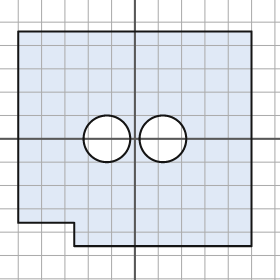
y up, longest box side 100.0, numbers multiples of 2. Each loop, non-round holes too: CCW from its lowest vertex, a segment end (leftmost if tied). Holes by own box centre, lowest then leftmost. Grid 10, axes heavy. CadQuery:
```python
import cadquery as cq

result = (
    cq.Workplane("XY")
    .moveTo(-26.0, -46.0)
    .lineTo(50.0, -46.0)
    .lineTo(50.0, 46.0)
    .lineTo(-50.0, 46.0)
    .lineTo(-50.0, -36.0)
    .lineTo(-26.0, -36.0)
    .close()
    .moveTo(-12.0, 0.0)
    .circle(10.0)
    .moveTo(12.0, 0.0)
    .circle(10.0)
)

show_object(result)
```